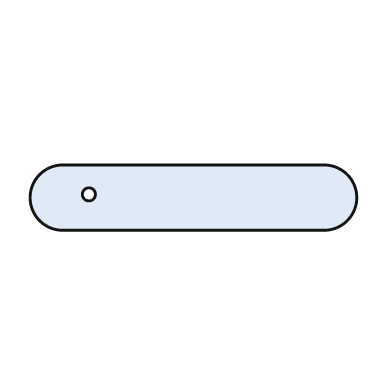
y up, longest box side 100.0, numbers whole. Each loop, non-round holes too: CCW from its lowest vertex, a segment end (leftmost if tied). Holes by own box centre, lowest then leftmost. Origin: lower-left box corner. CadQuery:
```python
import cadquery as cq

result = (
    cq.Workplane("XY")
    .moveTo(10.0, 0.0)
    .lineTo(90.0, 0.0)
    .threePointArc((100.0, 10.0), (90.0, 20.0))
    .lineTo(10.0, 20.0)
    .threePointArc((0.0, 10.0), (10.0, 0.0))
    .close()
    .moveTo(18.0, 11.0)
    .circle(2.0)
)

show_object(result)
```